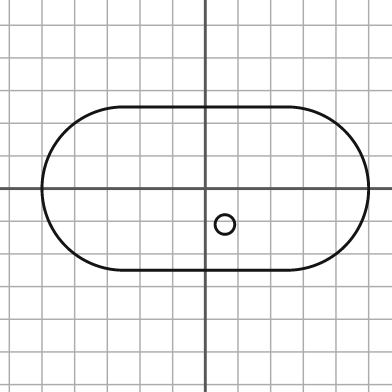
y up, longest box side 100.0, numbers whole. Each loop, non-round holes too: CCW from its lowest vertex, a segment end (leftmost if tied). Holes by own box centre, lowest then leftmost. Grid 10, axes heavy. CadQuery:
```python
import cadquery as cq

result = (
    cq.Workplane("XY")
    .moveTo(-25.0, -25.0)
    .lineTo(25.0, -25.0)
    .threePointArc((50.0, 0.0), (25.0, 25.0))
    .lineTo(-25.0, 25.0)
    .threePointArc((-50.0, 0.0), (-25.0, -25.0))
    .close()
    .moveTo(6.0, -11.0)
    .circle(3.0)
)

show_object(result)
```